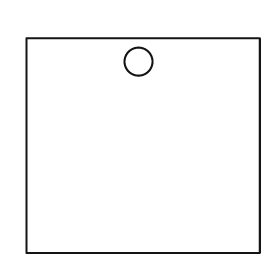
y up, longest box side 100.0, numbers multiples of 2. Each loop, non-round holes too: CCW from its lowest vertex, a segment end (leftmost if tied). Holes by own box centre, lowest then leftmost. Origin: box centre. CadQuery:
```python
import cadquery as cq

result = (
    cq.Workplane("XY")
    .moveTo(-50.0, -46.0)
    .lineTo(50.0, -46.0)
    .lineTo(50.0, 46.0)
    .lineTo(-50.0, 46.0)
    .close()
    .moveTo(-2.0, 36.0)
    .circle(6.0)
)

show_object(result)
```